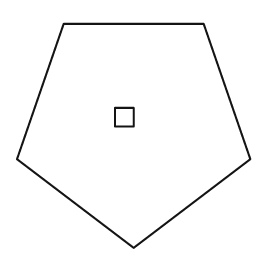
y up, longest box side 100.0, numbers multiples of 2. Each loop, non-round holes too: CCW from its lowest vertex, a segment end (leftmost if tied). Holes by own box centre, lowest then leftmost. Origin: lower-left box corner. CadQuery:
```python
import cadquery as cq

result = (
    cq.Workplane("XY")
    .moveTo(50.0, 0.0)
    .lineTo(100.0, 38.0)
    .lineTo(80.0, 96.0)
    .lineTo(20.0, 96.0)
    .lineTo(0.0, 38.0)
    .close()
    .moveTo(42.0, 52.0)
    .lineTo(50.0, 52.0)
    .lineTo(50.0, 60.0)
    .lineTo(42.0, 60.0)
    .close()
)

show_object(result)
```